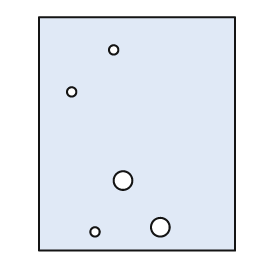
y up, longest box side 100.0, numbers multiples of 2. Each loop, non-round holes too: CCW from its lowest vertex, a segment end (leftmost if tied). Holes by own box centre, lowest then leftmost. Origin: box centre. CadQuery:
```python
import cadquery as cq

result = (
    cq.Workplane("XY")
    .moveTo(-42.0, -50.0)
    .lineTo(42.0, -50.0)
    .lineTo(42.0, 50.0)
    .lineTo(-42.0, 50.0)
    .close()
    .moveTo(-18.0, -42.0)
    .circle(2.0)
    .moveTo(10.0, -40.0)
    .circle(4.0)
    .moveTo(-6.0, -20.0)
    .circle(4.0)
    .moveTo(-28.0, 18.0)
    .circle(2.0)
    .moveTo(-10.0, 36.0)
    .circle(2.0)
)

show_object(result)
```